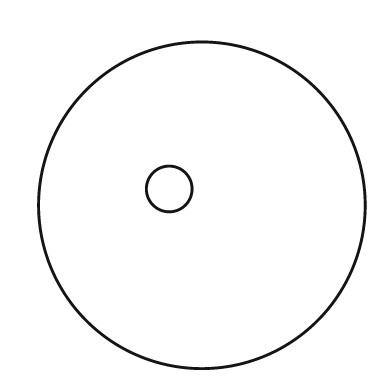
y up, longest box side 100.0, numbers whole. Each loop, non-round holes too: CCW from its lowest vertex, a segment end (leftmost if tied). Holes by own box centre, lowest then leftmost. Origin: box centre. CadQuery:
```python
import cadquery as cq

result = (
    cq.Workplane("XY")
    .moveTo(0.0, 0.0)
    .circle(50.0)
    .moveTo(-10.0, 5.0)
    .circle(7.0)
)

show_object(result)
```